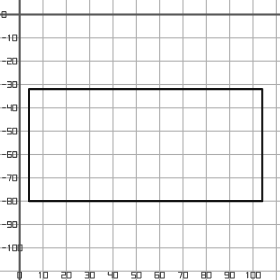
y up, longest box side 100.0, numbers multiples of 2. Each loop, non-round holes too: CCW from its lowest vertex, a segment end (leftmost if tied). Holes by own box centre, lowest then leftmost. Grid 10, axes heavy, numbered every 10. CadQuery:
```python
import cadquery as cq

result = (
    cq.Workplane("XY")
    .moveTo(4.0, -80.0)
    .lineTo(104.0, -80.0)
    .lineTo(104.0, -32.0)
    .lineTo(4.0, -32.0)
    .close()
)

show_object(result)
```